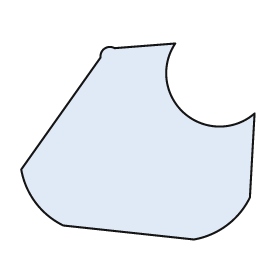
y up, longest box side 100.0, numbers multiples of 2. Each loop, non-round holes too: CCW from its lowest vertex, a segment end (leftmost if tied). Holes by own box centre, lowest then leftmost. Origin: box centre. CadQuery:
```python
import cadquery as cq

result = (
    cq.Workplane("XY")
    .moveTo(24.0, -42.0)
    .threePointArc((38.0, -36.0), (48.0, -24.0))
    .lineTo(50.0, 12.0)
    .threePointArc((20.0, 12.0), (16.0, 42.0))
    .lineTo(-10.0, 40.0)
    .threePointArc((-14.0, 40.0), (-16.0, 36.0))
    .lineTo(-50.0, -12.0)
    .threePointArc((-44.0, -26.0), (-32.0, -36.0))
    .close()
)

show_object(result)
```